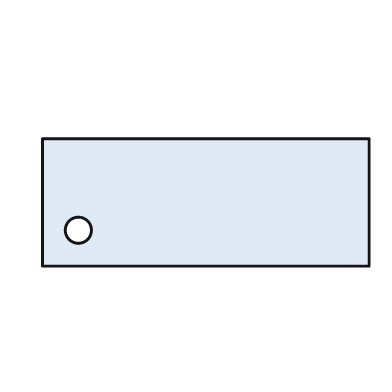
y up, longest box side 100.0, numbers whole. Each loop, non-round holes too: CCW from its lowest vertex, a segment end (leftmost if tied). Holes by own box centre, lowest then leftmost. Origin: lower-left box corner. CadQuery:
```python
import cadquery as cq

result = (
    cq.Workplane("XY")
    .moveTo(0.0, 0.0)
    .lineTo(100.0, 0.0)
    .lineTo(100.0, 39.0)
    .lineTo(0.0, 39.0)
    .close()
    .moveTo(11.0, 11.0)
    .circle(4.0)
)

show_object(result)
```